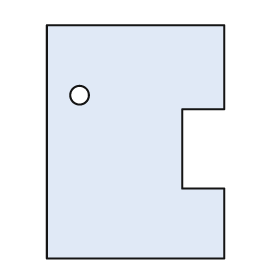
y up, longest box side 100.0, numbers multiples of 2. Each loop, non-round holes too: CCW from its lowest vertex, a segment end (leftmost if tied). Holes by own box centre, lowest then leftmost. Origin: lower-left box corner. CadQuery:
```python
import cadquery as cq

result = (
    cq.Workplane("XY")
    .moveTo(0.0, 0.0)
    .lineTo(76.0, 0.0)
    .lineTo(76.0, 30.0)
    .lineTo(58.0, 30.0)
    .lineTo(58.0, 64.0)
    .lineTo(76.0, 64.0)
    .lineTo(76.0, 100.0)
    .lineTo(0.0, 100.0)
    .close()
    .moveTo(14.0, 70.0)
    .circle(4.0)
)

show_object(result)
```